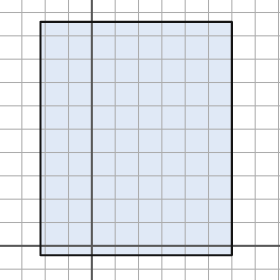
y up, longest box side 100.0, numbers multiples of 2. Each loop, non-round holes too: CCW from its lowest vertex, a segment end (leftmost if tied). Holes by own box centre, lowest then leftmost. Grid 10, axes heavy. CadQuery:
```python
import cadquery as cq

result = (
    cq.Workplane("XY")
    .moveTo(-22.0, -4.0)
    .lineTo(60.0, -4.0)
    .lineTo(60.0, 96.0)
    .lineTo(-22.0, 96.0)
    .close()
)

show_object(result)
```